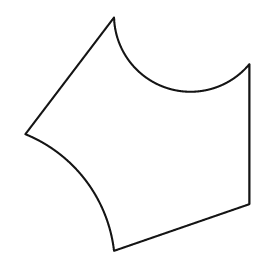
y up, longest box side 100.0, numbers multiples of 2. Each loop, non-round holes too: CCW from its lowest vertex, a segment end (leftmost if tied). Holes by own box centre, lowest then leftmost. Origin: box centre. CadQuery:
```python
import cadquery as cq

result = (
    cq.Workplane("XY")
    .moveTo(-10.0, -50.0)
    .lineTo(48.0, -30.0)
    .lineTo(48.0, 30.0)
    .threePointArc((12.0, 20.0), (-10.0, 50.0))
    .lineTo(-48.0, 0.0)
    .threePointArc((-22.0, -20.0), (-10.0, -50.0))
    .close()
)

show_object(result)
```